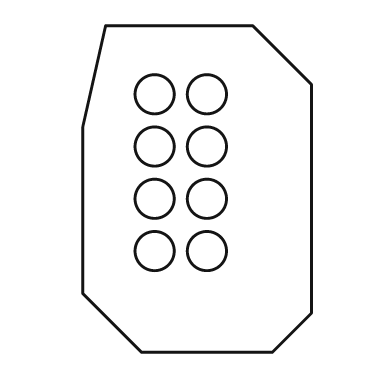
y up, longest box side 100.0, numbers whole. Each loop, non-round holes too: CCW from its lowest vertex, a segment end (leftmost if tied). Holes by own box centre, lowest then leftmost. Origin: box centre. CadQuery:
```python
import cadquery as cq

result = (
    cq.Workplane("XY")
    .moveTo(-17.0, -50.0)
    .lineTo(23.0, -50.0)
    .lineTo(35.0, -38.0)
    .lineTo(35.0, 32.0)
    .lineTo(17.0, 50.0)
    .lineTo(-28.0, 50.0)
    .lineTo(-35.0, 19.0)
    .lineTo(-35.0, -32.0)
    .close()
    .moveTo(-13.0, -19.0)
    .circle(6.0)
    .moveTo(3.0, -19.0)
    .circle(6.0)
    .moveTo(-13.0, -3.0)
    .circle(6.0)
    .moveTo(3.0, -3.0)
    .circle(6.0)
    .moveTo(-13.0, 13.0)
    .circle(6.0)
    .moveTo(3.0, 13.0)
    .circle(6.0)
    .moveTo(-13.0, 29.0)
    .circle(6.0)
    .moveTo(3.0, 29.0)
    .circle(6.0)
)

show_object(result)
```